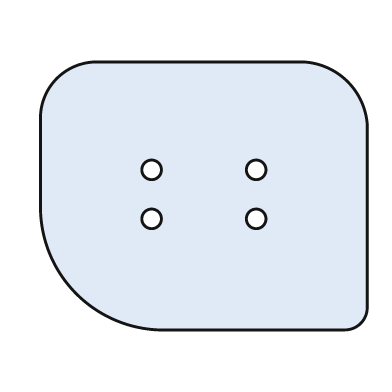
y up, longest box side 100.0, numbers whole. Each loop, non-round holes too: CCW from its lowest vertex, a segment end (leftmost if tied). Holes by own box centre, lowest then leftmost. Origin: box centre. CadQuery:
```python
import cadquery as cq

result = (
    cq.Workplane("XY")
    .moveTo(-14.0, -41.0)
    .lineTo(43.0, -41.0)
    .threePointArc((48.0, -39.0), (50.0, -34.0))
    .lineTo(50.0, 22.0)
    .threePointArc((44.0, 35.0), (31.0, 41.0))
    .lineTo(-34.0, 41.0)
    .threePointArc((-45.0, 36.0), (-50.0, 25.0))
    .lineTo(-50.0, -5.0)
    .threePointArc((-39.0, -30.0), (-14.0, -41.0))
    .close()
    .moveTo(-16.0, -7.0)
    .circle(3.0)
    .moveTo(16.0, -7.0)
    .circle(3.0)
    .moveTo(-16.0, 8.0)
    .circle(3.0)
    .moveTo(16.0, 8.0)
    .circle(3.0)
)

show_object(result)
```